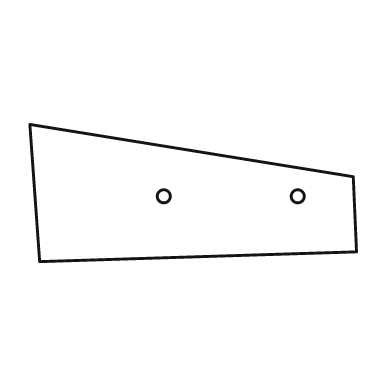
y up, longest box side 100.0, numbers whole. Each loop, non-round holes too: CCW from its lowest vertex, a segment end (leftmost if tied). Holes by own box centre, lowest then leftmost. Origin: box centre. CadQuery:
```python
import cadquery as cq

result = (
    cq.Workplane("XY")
    .moveTo(-47.0, -21.0)
    .lineTo(50.0, -18.0)
    .lineTo(49.0, 5.0)
    .lineTo(-50.0, 21.0)
    .close()
    .moveTo(-9.0, -1.0)
    .circle(2.0)
    .moveTo(32.0, -1.0)
    .circle(2.0)
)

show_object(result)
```